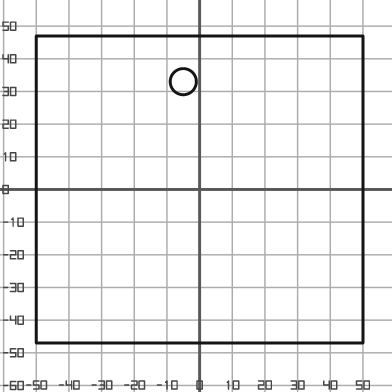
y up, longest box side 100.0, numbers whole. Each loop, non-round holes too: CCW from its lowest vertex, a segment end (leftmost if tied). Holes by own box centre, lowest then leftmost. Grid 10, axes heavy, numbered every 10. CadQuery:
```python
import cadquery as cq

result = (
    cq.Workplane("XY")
    .moveTo(-50.0, -47.0)
    .lineTo(50.0, -47.0)
    .lineTo(50.0, 47.0)
    .lineTo(-50.0, 47.0)
    .close()
    .moveTo(-5.0, 33.0)
    .circle(4.0)
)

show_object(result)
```